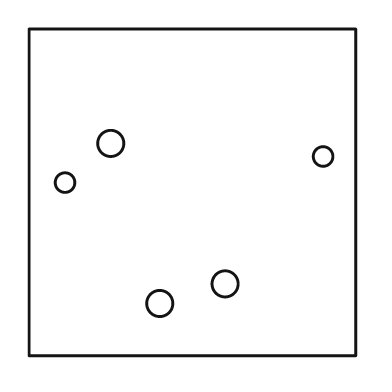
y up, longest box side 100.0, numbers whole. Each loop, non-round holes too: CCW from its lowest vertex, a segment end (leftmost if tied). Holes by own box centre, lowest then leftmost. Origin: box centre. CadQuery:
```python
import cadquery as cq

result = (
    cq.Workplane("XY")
    .moveTo(-50.0, -50.0)
    .lineTo(50.0, -50.0)
    .lineTo(50.0, 50.0)
    .lineTo(-50.0, 50.0)
    .close()
    .moveTo(-10.0, -34.0)
    .circle(4.0)
    .moveTo(10.0, -28.0)
    .circle(4.0)
    .moveTo(-39.0, 3.0)
    .circle(3.0)
    .moveTo(40.0, 11.0)
    .circle(3.0)
    .moveTo(-25.0, 15.0)
    .circle(4.0)
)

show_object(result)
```